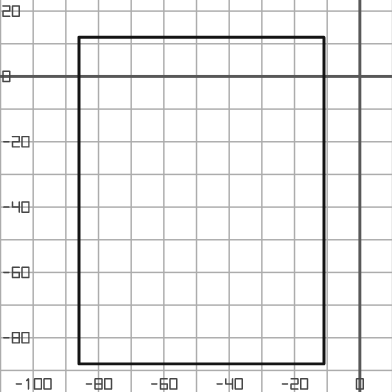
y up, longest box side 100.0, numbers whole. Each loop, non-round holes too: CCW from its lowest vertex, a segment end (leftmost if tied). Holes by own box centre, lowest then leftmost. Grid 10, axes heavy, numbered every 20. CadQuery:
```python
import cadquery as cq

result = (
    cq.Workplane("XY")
    .moveTo(-86.0, -88.0)
    .lineTo(-11.0, -88.0)
    .lineTo(-11.0, 12.0)
    .lineTo(-86.0, 12.0)
    .close()
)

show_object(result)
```